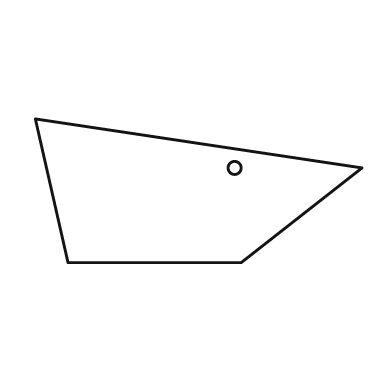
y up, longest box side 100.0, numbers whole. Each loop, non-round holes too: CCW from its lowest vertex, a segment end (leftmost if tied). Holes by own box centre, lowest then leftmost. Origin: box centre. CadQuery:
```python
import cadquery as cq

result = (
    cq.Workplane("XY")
    .moveTo(-40.0, -22.0)
    .lineTo(13.0, -22.0)
    .lineTo(50.0, 7.0)
    .lineTo(-50.0, 22.0)
    .close()
    .moveTo(11.0, 7.0)
    .circle(2.0)
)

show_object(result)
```